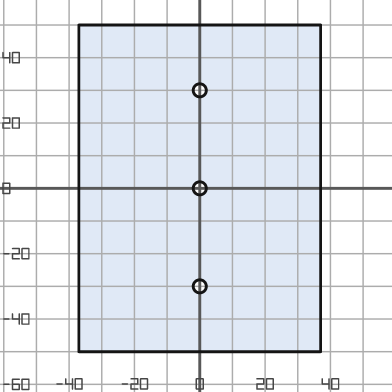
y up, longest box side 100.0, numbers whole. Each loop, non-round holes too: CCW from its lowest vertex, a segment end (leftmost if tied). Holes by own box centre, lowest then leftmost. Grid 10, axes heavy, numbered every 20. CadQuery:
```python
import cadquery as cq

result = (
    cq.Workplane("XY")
    .moveTo(-37.0, -50.0)
    .lineTo(37.0, -50.0)
    .lineTo(37.0, 50.0)
    .lineTo(-37.0, 50.0)
    .close()
    .moveTo(0.0, -30.0)
    .circle(2.0)
    .moveTo(0.0, 0.0)
    .circle(2.0)
    .moveTo(0.0, 30.0)
    .circle(2.0)
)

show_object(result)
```